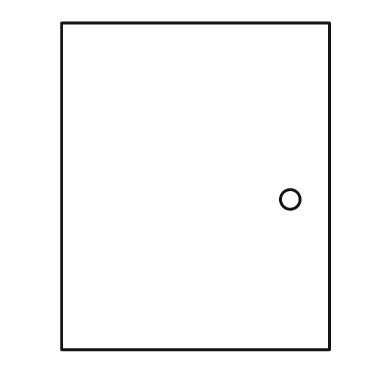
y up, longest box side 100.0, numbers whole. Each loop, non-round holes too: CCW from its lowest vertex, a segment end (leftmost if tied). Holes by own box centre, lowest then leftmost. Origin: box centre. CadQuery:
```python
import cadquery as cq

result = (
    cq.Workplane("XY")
    .moveTo(-41.0, -50.0)
    .lineTo(41.0, -50.0)
    .lineTo(41.0, 50.0)
    .lineTo(-41.0, 50.0)
    .close()
    .moveTo(29.0, -4.0)
    .circle(3.0)
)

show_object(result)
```